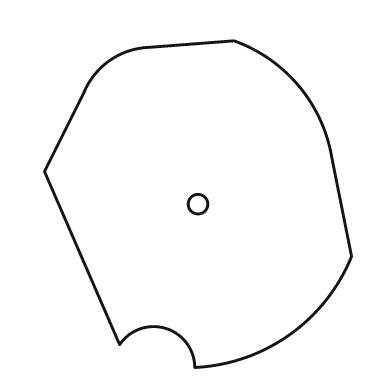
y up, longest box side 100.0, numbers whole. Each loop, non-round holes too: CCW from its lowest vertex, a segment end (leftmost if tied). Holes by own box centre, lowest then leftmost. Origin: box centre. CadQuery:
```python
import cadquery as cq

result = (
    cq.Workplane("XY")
    .moveTo(-1.0, -50.0)
    .threePointArc((28.0, -40.0), (47.0, -16.0))
    .lineTo(41.0, 14.0)
    .threePointArc((31.0, 36.0), (11.0, 50.0))
    .lineTo(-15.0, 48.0)
    .threePointArc((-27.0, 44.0), (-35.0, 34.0))
    .lineTo(-47.0, 10.0)
    .lineTo(-24.0, -43.0)
    .threePointArc((-10.0, -38.0), (-1.0, -50.0))
    .close()
    .moveTo(0.0, 0.0)
    .circle(3.0)
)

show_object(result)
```